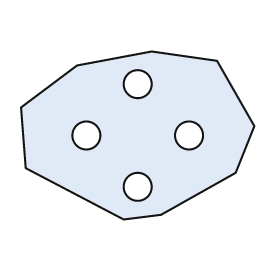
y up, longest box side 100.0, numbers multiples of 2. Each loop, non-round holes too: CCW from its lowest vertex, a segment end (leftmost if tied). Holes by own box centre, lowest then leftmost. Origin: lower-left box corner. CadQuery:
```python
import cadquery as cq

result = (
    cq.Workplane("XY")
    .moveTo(44.0, 0.0)
    .lineTo(60.0, 2.0)
    .lineTo(92.0, 20.0)
    .lineTo(100.0, 40.0)
    .lineTo(84.0, 68.0)
    .lineTo(56.0, 72.0)
    .lineTo(24.0, 66.0)
    .lineTo(0.0, 48.0)
    .lineTo(2.0, 22.0)
    .close()
    .moveTo(50.0, 14.0)
    .circle(6.0)
    .moveTo(28.0, 36.0)
    .circle(6.0)
    .moveTo(72.0, 36.0)
    .circle(6.0)
    .moveTo(50.0, 58.0)
    .circle(6.0)
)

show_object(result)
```